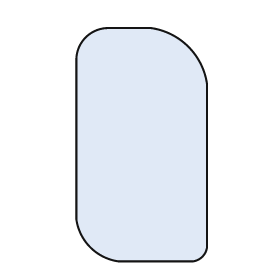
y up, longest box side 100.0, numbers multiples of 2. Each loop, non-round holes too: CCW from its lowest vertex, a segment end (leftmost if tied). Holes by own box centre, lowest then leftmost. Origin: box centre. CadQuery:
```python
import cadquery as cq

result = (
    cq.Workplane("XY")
    .moveTo(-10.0, -50.0)
    .lineTo(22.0, -50.0)
    .threePointArc((26.0, -48.0), (28.0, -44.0))
    .lineTo(28.0, 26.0)
    .threePointArc((20.0, 42.0), (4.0, 50.0))
    .lineTo(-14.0, 50.0)
    .threePointArc((-24.0, 46.0), (-28.0, 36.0))
    .lineTo(-28.0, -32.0)
    .threePointArc((-22.0, -44.0), (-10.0, -50.0))
    .close()
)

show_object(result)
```